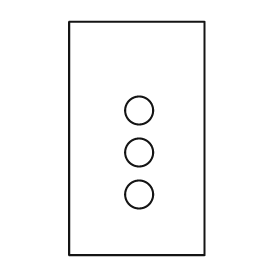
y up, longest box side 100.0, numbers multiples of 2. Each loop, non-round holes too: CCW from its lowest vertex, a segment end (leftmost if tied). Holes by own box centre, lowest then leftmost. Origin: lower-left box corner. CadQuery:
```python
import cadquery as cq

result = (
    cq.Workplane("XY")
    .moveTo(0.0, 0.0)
    .lineTo(58.0, 0.0)
    .lineTo(58.0, 100.0)
    .lineTo(0.0, 100.0)
    .close()
    .moveTo(30.0, 26.0)
    .circle(6.0)
    .moveTo(30.0, 44.0)
    .circle(6.0)
    .moveTo(30.0, 62.0)
    .circle(6.0)
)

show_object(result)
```